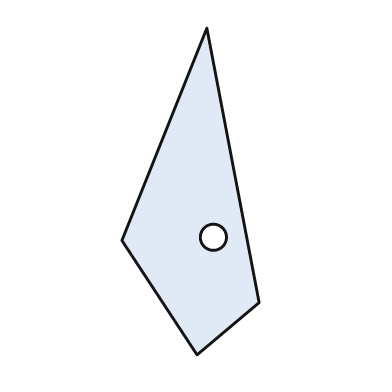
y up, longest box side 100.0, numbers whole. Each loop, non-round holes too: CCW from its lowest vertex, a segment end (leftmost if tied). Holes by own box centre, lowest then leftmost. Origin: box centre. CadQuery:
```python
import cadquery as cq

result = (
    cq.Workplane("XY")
    .moveTo(2.0, -50.0)
    .lineTo(21.0, -34.0)
    .lineTo(5.0, 50.0)
    .lineTo(-21.0, -15.0)
    .close()
    .moveTo(7.0, -14.0)
    .circle(4.0)
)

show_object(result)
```